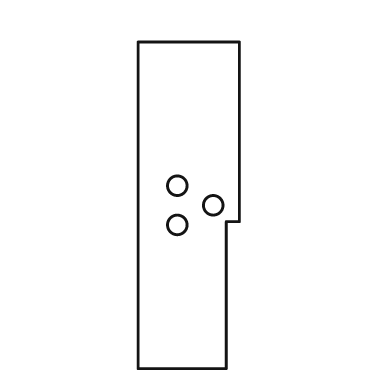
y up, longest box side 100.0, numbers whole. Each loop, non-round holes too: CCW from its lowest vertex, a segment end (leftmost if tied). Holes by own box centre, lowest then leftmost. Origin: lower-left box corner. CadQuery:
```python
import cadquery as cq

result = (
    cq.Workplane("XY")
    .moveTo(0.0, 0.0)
    .lineTo(27.0, 0.0)
    .lineTo(27.0, 45.0)
    .lineTo(31.0, 45.0)
    .lineTo(31.0, 100.0)
    .lineTo(0.0, 100.0)
    .close()
    .moveTo(12.0, 44.0)
    .circle(3.0)
    .moveTo(23.0, 50.0)
    .circle(3.0)
    .moveTo(12.0, 56.0)
    .circle(3.0)
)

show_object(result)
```